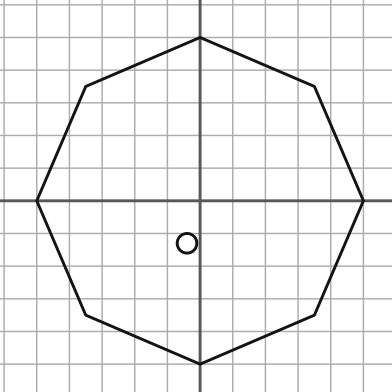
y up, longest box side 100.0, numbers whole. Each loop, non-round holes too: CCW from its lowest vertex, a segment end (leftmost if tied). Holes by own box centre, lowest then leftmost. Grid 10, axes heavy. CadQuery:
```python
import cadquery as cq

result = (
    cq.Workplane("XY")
    .moveTo(0.0, -50.0)
    .lineTo(35.0, -35.0)
    .lineTo(50.0, 0.0)
    .lineTo(35.0, 35.0)
    .lineTo(0.0, 50.0)
    .lineTo(-35.0, 35.0)
    .lineTo(-50.0, 0.0)
    .lineTo(-35.0, -35.0)
    .close()
    .moveTo(-4.0, -13.0)
    .circle(3.0)
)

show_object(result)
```